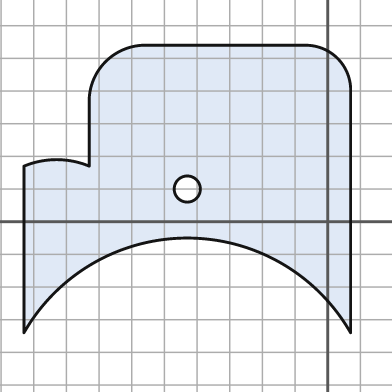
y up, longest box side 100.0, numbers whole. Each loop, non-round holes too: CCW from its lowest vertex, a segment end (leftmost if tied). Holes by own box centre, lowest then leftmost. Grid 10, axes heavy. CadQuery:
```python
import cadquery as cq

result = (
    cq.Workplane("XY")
    .moveTo(-93.0, -34.0)
    .threePointArc((-43.0, -5.0), (7.0, -34.0))
    .lineTo(7.0, 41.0)
    .threePointArc((3.0, 50.0), (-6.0, 54.0))
    .lineTo(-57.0, 54.0)
    .threePointArc((-68.0, 49.0), (-73.0, 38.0))
    .lineTo(-73.0, 17.0)
    .threePointArc((-83.0, 19.0), (-93.0, 17.0))
    .close()
    .moveTo(-43.0, 10.0)
    .circle(4.0)
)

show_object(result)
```